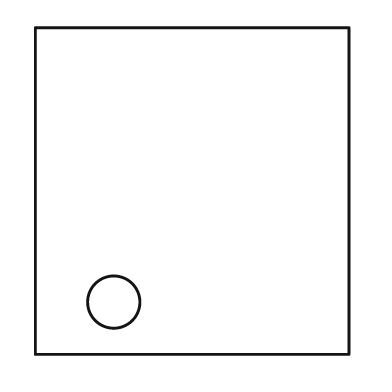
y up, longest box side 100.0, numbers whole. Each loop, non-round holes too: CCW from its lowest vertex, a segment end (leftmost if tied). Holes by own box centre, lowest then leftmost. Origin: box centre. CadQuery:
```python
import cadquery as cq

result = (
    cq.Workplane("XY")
    .moveTo(-48.0, -50.0)
    .lineTo(48.0, -50.0)
    .lineTo(48.0, 50.0)
    .lineTo(-48.0, 50.0)
    .close()
    .moveTo(-24.0, -34.0)
    .circle(8.0)
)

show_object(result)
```